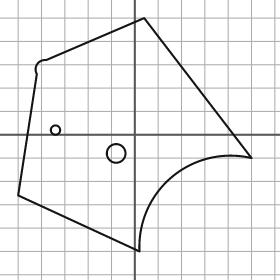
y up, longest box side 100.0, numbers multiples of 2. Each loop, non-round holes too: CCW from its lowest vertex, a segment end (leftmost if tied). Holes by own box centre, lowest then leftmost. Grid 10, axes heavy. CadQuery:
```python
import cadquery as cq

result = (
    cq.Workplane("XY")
    .moveTo(2.0, -50.0)
    .threePointArc((16.0, -18.0), (50.0, -10.0))
    .lineTo(4.0, 50.0)
    .lineTo(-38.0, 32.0)
    .threePointArc((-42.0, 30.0), (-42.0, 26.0))
    .lineTo(-50.0, -26.0)
    .close()
    .moveTo(-8.0, -8.0)
    .circle(4.0)
    .moveTo(-34.0, 2.0)
    .circle(2.0)
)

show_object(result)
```